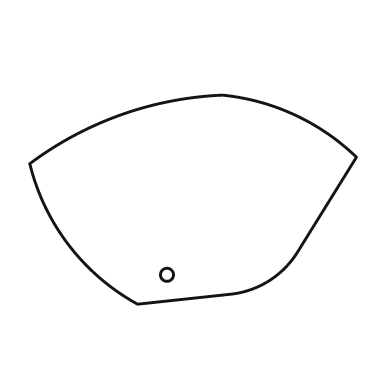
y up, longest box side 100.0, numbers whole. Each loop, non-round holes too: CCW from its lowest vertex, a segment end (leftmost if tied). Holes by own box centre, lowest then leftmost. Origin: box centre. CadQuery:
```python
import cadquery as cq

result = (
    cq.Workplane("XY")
    .moveTo(-17.0, -32.0)
    .lineTo(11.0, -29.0)
    .threePointArc((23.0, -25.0), (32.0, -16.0))
    .lineTo(50.0, 13.0)
    .threePointArc((31.0, 26.0), (9.0, 32.0))
    .threePointArc((-22.0, 26.0), (-50.0, 11.0))
    .threePointArc((-38.0, -14.0), (-17.0, -32.0))
    .close()
    .moveTo(-8.0, -23.0)
    .circle(2.0)
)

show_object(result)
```